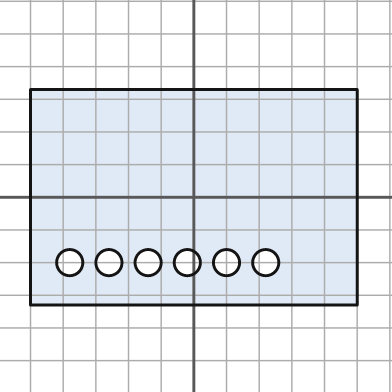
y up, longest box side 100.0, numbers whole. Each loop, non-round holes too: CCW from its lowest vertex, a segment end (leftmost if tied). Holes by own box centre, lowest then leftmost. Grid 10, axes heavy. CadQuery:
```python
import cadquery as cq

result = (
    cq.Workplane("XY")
    .moveTo(-50.0, -33.0)
    .lineTo(50.0, -33.0)
    .lineTo(50.0, 33.0)
    .lineTo(-50.0, 33.0)
    .close()
    .moveTo(-38.0, -20.0)
    .circle(4.0)
    .moveTo(-26.0, -20.0)
    .circle(4.0)
    .moveTo(-14.0, -20.0)
    .circle(4.0)
    .moveTo(-2.0, -20.0)
    .circle(4.0)
    .moveTo(10.0, -20.0)
    .circle(4.0)
    .moveTo(22.0, -20.0)
    .circle(4.0)
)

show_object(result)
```